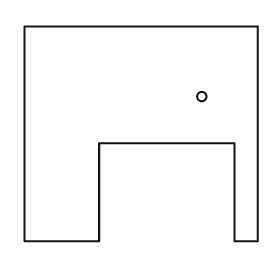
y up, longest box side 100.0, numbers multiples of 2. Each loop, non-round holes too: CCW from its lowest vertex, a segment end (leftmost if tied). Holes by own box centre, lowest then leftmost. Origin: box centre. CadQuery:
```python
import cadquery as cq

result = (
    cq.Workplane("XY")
    .moveTo(-50.0, -46.0)
    .lineTo(-18.0, -46.0)
    .lineTo(-18.0, -4.0)
    .lineTo(40.0, -4.0)
    .lineTo(40.0, -46.0)
    .lineTo(50.0, -46.0)
    .lineTo(50.0, 46.0)
    .lineTo(-50.0, 46.0)
    .close()
    .moveTo(26.0, 16.0)
    .circle(2.0)
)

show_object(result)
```